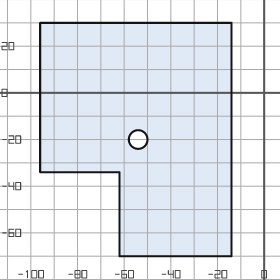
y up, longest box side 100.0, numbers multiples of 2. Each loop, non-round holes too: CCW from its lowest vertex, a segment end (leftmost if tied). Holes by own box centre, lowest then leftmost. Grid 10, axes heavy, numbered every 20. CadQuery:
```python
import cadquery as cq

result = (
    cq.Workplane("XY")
    .moveTo(-62.0, -70.0)
    .lineTo(-14.0, -70.0)
    .lineTo(-14.0, 30.0)
    .lineTo(-96.0, 30.0)
    .lineTo(-96.0, -34.0)
    .lineTo(-62.0, -34.0)
    .close()
    .moveTo(-54.0, -20.0)
    .circle(4.0)
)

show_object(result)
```